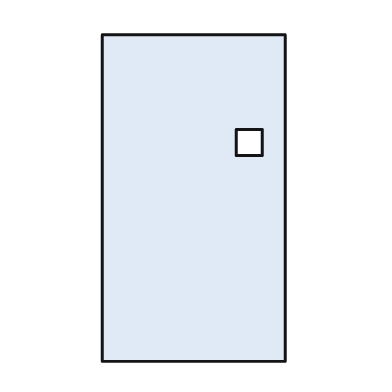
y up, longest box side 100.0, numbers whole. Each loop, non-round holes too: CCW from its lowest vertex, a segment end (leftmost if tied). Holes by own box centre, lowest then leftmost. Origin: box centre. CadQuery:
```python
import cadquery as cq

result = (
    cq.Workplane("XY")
    .moveTo(-28.0, -50.0)
    .lineTo(28.0, -50.0)
    .lineTo(28.0, 50.0)
    .lineTo(-28.0, 50.0)
    .close()
    .moveTo(13.0, 13.0)
    .lineTo(21.0, 13.0)
    .lineTo(21.0, 21.0)
    .lineTo(13.0, 21.0)
    .close()
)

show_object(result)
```